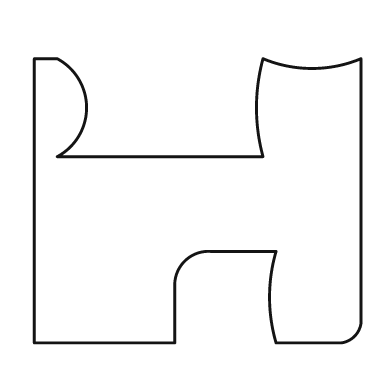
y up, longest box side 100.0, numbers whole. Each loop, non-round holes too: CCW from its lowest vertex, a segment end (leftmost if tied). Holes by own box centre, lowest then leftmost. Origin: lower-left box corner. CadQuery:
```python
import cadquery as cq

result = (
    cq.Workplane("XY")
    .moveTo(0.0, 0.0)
    .lineTo(43.0, 0.0)
    .lineTo(43.0, 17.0)
    .threePointArc((46.0, 25.0), (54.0, 28.0))
    .lineTo(74.0, 28.0)
    .threePointArc((72.0, 14.0), (74.0, 0.0))
    .lineTo(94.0, 0.0)
    .threePointArc((98.0, 2.0), (100.0, 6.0))
    .lineTo(100.0, 87.0)
    .threePointArc((85.0, 84.0), (70.0, 87.0))
    .threePointArc((68.0, 72.0), (70.0, 57.0))
    .lineTo(7.0, 57.0)
    .threePointArc((16.0, 72.0), (7.0, 87.0))
    .lineTo(0.0, 87.0)
    .close()
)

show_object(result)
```